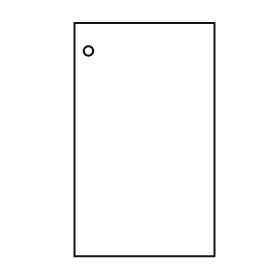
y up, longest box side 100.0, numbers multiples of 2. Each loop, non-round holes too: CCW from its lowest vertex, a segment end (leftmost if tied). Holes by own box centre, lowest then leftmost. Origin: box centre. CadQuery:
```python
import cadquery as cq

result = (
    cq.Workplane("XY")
    .moveTo(-30.0, -50.0)
    .lineTo(30.0, -50.0)
    .lineTo(30.0, 50.0)
    .lineTo(-30.0, 50.0)
    .close()
    .moveTo(-24.0, 38.0)
    .circle(2.0)
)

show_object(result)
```